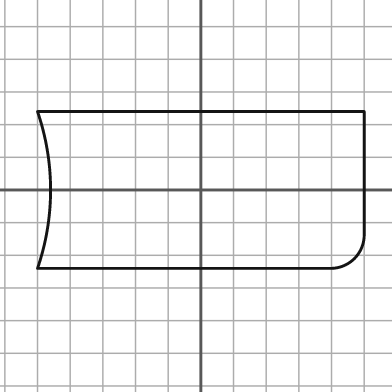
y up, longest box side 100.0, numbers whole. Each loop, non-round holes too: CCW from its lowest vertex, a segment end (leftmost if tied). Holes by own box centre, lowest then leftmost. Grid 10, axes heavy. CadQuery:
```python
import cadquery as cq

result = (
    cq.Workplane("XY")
    .moveTo(-50.0, -24.0)
    .lineTo(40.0, -24.0)
    .threePointArc((47.0, -21.0), (50.0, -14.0))
    .lineTo(50.0, 24.0)
    .lineTo(-50.0, 24.0)
    .threePointArc((-46.0, 0.0), (-50.0, -24.0))
    .close()
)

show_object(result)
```